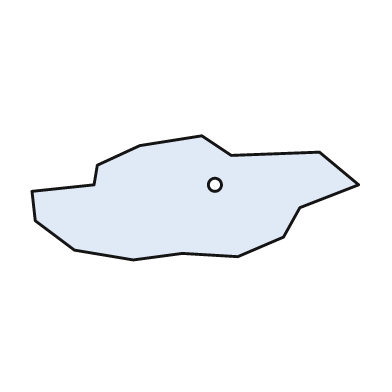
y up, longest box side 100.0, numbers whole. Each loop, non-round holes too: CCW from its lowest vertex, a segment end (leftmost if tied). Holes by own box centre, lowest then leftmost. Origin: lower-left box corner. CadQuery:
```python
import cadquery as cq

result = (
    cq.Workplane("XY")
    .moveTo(31.0, 0.0)
    .lineTo(46.0, 2.0)
    .lineTo(63.0, 1.0)
    .lineTo(77.0, 7.0)
    .lineTo(82.0, 16.0)
    .lineTo(100.0, 23.0)
    .lineTo(88.0, 33.0)
    .lineTo(61.0, 32.0)
    .lineTo(52.0, 38.0)
    .lineTo(33.0, 35.0)
    .lineTo(20.0, 29.0)
    .lineTo(19.0, 23.0)
    .lineTo(0.0, 21.0)
    .lineTo(1.0, 12.0)
    .lineTo(13.0, 3.0)
    .close()
    .moveTo(56.0, 23.0)
    .circle(2.0)
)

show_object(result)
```